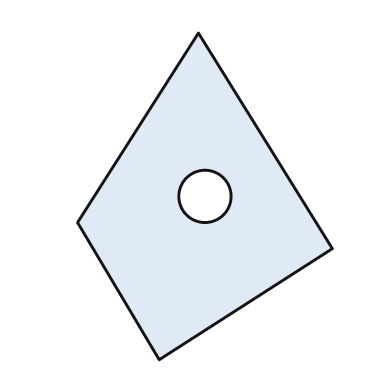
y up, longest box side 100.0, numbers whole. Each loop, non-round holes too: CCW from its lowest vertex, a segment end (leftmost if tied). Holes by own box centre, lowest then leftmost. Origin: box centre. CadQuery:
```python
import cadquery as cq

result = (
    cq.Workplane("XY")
    .moveTo(-14.0, -50.0)
    .lineTo(39.0, -16.0)
    .lineTo(-2.0, 50.0)
    .lineTo(-39.0, -8.0)
    .close()
    .moveTo(0.0, 0.0)
    .circle(8.0)
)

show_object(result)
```